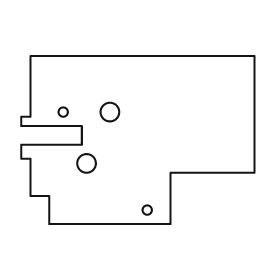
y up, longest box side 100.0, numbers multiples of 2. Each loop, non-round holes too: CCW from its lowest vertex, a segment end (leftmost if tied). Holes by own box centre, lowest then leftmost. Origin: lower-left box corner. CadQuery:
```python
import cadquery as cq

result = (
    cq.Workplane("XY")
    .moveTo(12.0, 0.0)
    .lineTo(64.0, 0.0)
    .lineTo(64.0, 22.0)
    .lineTo(100.0, 22.0)
    .lineTo(100.0, 72.0)
    .lineTo(4.0, 72.0)
    .lineTo(4.0, 46.0)
    .lineTo(0.0, 46.0)
    .lineTo(0.0, 42.0)
    .lineTo(26.0, 42.0)
    .lineTo(26.0, 34.0)
    .lineTo(0.0, 34.0)
    .lineTo(0.0, 28.0)
    .lineTo(4.0, 28.0)
    .lineTo(4.0, 12.0)
    .lineTo(12.0, 12.0)
    .close()
    .moveTo(54.0, 6.0)
    .circle(2.0)
    .moveTo(28.0, 26.0)
    .circle(4.0)
    .moveTo(18.0, 48.0)
    .circle(2.0)
    .moveTo(38.0, 48.0)
    .circle(4.0)
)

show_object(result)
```